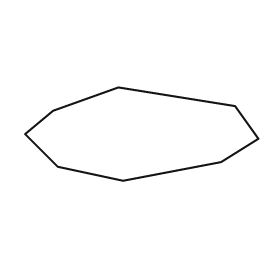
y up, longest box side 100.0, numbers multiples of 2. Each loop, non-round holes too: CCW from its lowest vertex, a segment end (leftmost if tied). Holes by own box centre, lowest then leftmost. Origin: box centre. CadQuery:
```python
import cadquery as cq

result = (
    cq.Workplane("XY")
    .moveTo(-8.0, -20.0)
    .lineTo(34.0, -12.0)
    .lineTo(50.0, -2.0)
    .lineTo(40.0, 12.0)
    .lineTo(-10.0, 20.0)
    .lineTo(-38.0, 10.0)
    .lineTo(-50.0, 0.0)
    .lineTo(-36.0, -14.0)
    .close()
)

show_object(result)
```